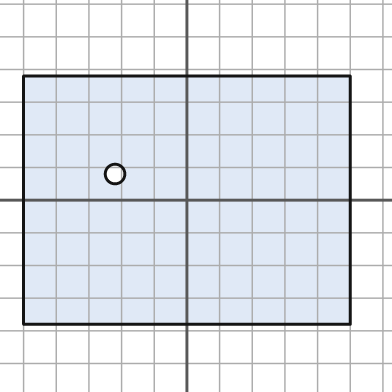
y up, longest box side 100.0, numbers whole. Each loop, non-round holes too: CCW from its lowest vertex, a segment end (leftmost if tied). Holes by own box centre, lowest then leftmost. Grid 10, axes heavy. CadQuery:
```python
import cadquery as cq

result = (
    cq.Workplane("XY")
    .moveTo(-50.0, -38.0)
    .lineTo(50.0, -38.0)
    .lineTo(50.0, 38.0)
    .lineTo(-50.0, 38.0)
    .close()
    .moveTo(-22.0, 8.0)
    .circle(3.0)
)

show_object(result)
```